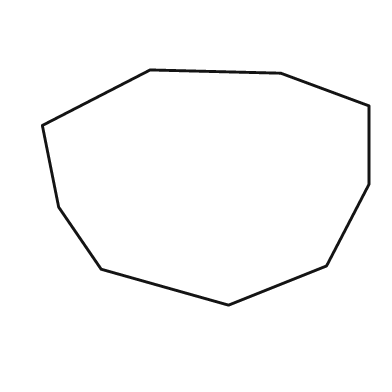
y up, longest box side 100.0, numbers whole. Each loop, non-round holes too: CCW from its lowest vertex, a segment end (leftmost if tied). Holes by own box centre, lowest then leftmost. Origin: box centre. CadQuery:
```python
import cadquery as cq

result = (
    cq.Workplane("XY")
    .moveTo(7.0, -36.0)
    .lineTo(37.0, -24.0)
    .lineTo(50.0, 1.0)
    .lineTo(50.0, 25.0)
    .lineTo(23.0, 35.0)
    .lineTo(-17.0, 36.0)
    .lineTo(-50.0, 19.0)
    .lineTo(-45.0, -6.0)
    .lineTo(-32.0, -25.0)
    .close()
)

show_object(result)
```